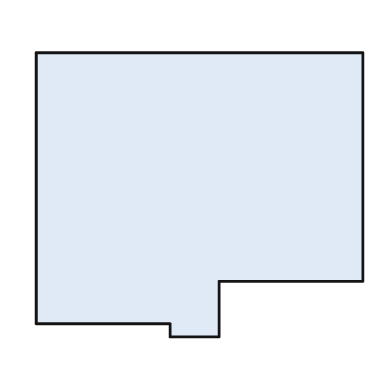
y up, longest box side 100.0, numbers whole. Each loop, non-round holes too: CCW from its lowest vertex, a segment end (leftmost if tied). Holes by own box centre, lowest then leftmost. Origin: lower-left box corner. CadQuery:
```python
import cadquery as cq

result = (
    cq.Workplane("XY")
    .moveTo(41.0, 0.0)
    .lineTo(56.0, 0.0)
    .lineTo(56.0, 17.0)
    .lineTo(100.0, 17.0)
    .lineTo(100.0, 87.0)
    .lineTo(0.0, 87.0)
    .lineTo(0.0, 4.0)
    .lineTo(41.0, 4.0)
    .close()
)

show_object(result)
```